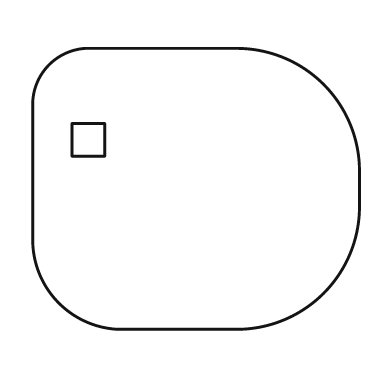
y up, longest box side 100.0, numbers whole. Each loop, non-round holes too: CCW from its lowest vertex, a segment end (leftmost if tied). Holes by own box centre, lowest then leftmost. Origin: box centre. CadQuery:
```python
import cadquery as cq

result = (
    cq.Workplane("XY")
    .moveTo(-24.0, -43.0)
    .lineTo(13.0, -43.0)
    .threePointArc((39.0, -32.0), (50.0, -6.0))
    .lineTo(50.0, 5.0)
    .threePointArc((39.0, 32.0), (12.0, 43.0))
    .lineTo(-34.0, 43.0)
    .threePointArc((-45.0, 38.0), (-50.0, 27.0))
    .lineTo(-50.0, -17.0)
    .threePointArc((-42.0, -35.0), (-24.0, -43.0))
    .close()
    .moveTo(-38.0, 10.0)
    .lineTo(-28.0, 10.0)
    .lineTo(-28.0, 20.0)
    .lineTo(-38.0, 20.0)
    .close()
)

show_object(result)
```